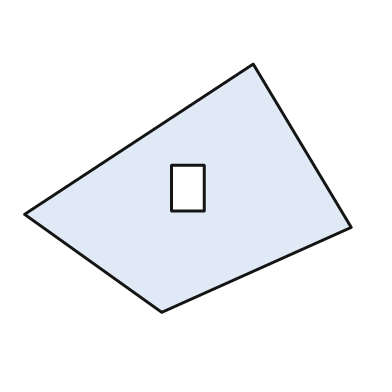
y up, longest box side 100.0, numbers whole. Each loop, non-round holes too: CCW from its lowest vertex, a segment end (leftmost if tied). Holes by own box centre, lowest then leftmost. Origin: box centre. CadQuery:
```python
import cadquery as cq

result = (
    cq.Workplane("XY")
    .moveTo(-8.0, -38.0)
    .lineTo(50.0, -12.0)
    .lineTo(20.0, 38.0)
    .lineTo(-50.0, -8.0)
    .close()
    .moveTo(-5.0, -7.0)
    .lineTo(5.0, -7.0)
    .lineTo(5.0, 7.0)
    .lineTo(-5.0, 7.0)
    .close()
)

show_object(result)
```